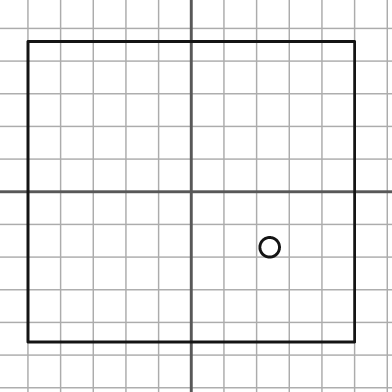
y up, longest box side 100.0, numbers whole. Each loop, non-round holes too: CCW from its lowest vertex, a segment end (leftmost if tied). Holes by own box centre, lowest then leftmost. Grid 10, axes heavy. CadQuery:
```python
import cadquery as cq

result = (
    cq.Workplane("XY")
    .moveTo(-50.0, -46.0)
    .lineTo(50.0, -46.0)
    .lineTo(50.0, 46.0)
    .lineTo(-50.0, 46.0)
    .close()
    .moveTo(24.0, -17.0)
    .circle(3.0)
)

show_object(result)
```